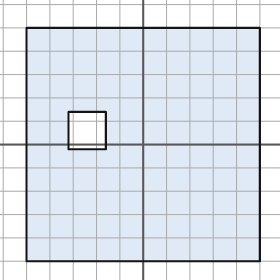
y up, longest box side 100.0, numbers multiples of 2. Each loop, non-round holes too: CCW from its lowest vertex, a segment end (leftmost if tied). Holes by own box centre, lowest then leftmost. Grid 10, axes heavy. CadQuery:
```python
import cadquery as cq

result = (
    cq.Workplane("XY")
    .moveTo(-50.0, -50.0)
    .lineTo(50.0, -50.0)
    .lineTo(50.0, 50.0)
    .lineTo(-50.0, 50.0)
    .close()
    .moveTo(-32.0, -2.0)
    .lineTo(-16.0, -2.0)
    .lineTo(-16.0, 14.0)
    .lineTo(-32.0, 14.0)
    .close()
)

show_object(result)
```